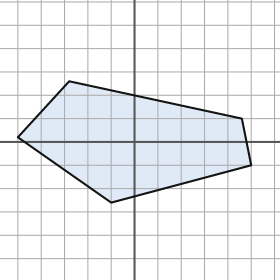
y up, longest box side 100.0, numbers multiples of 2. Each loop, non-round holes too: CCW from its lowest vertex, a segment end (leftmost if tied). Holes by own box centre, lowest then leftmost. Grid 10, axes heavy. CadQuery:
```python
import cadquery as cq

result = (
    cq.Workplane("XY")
    .moveTo(-10.0, -26.0)
    .lineTo(50.0, -10.0)
    .lineTo(46.0, 10.0)
    .lineTo(-28.0, 26.0)
    .lineTo(-50.0, 2.0)
    .close()
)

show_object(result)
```